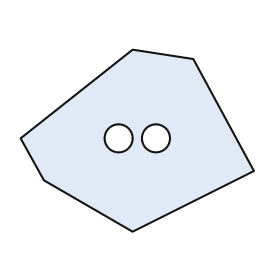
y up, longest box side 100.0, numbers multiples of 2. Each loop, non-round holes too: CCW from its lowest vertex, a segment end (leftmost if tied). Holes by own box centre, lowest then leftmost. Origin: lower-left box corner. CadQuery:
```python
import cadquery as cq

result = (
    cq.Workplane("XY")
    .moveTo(48.0, 0.0)
    .lineTo(100.0, 26.0)
    .lineTo(74.0, 74.0)
    .lineTo(48.0, 78.0)
    .lineTo(0.0, 40.0)
    .lineTo(10.0, 22.0)
    .close()
    .moveTo(42.0, 40.0)
    .circle(6.0)
    .moveTo(58.0, 40.0)
    .circle(6.0)
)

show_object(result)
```